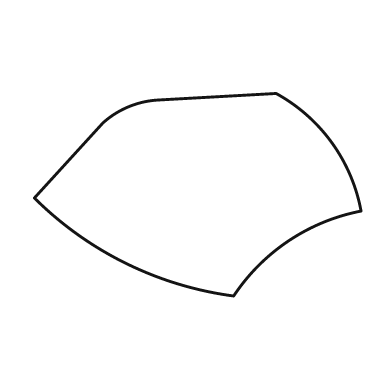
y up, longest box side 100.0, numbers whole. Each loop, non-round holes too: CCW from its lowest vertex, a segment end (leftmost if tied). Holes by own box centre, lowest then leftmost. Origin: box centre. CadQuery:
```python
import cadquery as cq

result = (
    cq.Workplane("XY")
    .moveTo(11.0, -31.0)
    .threePointArc((28.0, -14.0), (50.0, -5.0))
    .threePointArc((41.0, 16.0), (24.0, 31.0))
    .lineTo(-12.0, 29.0)
    .threePointArc((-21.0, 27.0), (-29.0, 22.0))
    .lineTo(-50.0, -1.0)
    .threePointArc((-22.0, -21.0), (11.0, -31.0))
    .close()
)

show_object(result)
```